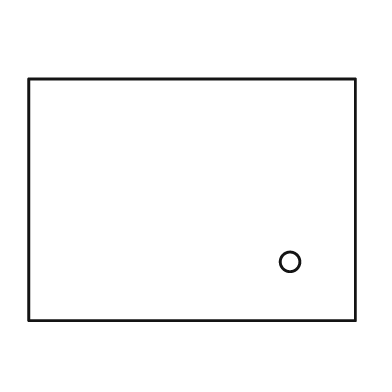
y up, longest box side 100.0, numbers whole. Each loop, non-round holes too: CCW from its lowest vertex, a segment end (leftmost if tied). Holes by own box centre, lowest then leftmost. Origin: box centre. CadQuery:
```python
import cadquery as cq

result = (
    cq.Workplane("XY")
    .moveTo(-50.0, -37.0)
    .lineTo(50.0, -37.0)
    .lineTo(50.0, 37.0)
    .lineTo(-50.0, 37.0)
    .close()
    .moveTo(30.0, -19.0)
    .circle(3.0)
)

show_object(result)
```